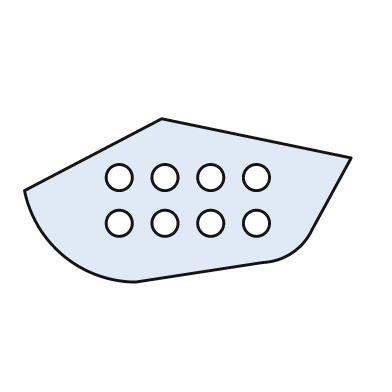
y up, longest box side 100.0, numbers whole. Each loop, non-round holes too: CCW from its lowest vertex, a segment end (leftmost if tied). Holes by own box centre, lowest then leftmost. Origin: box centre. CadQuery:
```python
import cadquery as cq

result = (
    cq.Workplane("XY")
    .moveTo(-16.0, -25.0)
    .lineTo(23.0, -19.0)
    .threePointArc((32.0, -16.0), (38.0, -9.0))
    .lineTo(50.0, 13.0)
    .lineTo(-8.0, 25.0)
    .lineTo(-50.0, 3.0)
    .threePointArc((-38.0, -17.0), (-16.0, -25.0))
    .close()
    .moveTo(-21.0, -7.0)
    .circle(4.0)
    .moveTo(-7.0, -7.0)
    .circle(4.0)
    .moveTo(7.0, -7.0)
    .circle(4.0)
    .moveTo(21.0, -7.0)
    .circle(4.0)
    .moveTo(-21.0, 7.0)
    .circle(4.0)
    .moveTo(-7.0, 7.0)
    .circle(4.0)
    .moveTo(7.0, 7.0)
    .circle(4.0)
    .moveTo(21.0, 7.0)
    .circle(4.0)
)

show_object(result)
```